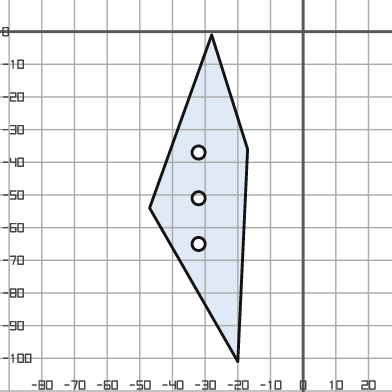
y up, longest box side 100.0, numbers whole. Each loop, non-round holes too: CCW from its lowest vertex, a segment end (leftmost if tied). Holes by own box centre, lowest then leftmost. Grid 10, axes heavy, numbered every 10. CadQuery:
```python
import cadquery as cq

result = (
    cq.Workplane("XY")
    .moveTo(-20.0, -101.0)
    .lineTo(-17.0, -36.0)
    .lineTo(-28.0, -1.0)
    .lineTo(-47.0, -54.0)
    .close()
    .moveTo(-32.0, -65.0)
    .circle(2.0)
    .moveTo(-32.0, -51.0)
    .circle(2.0)
    .moveTo(-32.0, -37.0)
    .circle(2.0)
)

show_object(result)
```